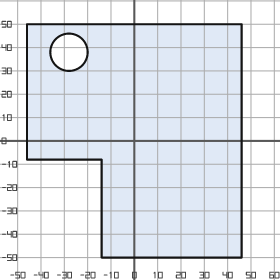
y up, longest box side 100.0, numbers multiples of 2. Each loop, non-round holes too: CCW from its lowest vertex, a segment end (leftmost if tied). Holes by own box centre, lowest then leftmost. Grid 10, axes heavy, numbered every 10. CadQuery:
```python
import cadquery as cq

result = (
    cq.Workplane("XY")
    .moveTo(-14.0, -50.0)
    .lineTo(46.0, -50.0)
    .lineTo(46.0, 50.0)
    .lineTo(-46.0, 50.0)
    .lineTo(-46.0, -8.0)
    .lineTo(-14.0, -8.0)
    .close()
    .moveTo(-28.0, 38.0)
    .circle(8.0)
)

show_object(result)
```